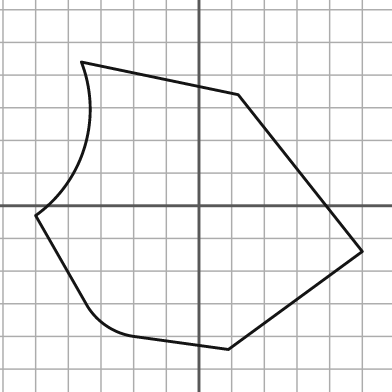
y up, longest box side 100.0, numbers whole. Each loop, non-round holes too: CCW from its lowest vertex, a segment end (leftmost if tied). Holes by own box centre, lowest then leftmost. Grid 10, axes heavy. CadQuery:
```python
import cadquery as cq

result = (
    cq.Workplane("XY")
    .moveTo(9.0, -44.0)
    .lineTo(50.0, -14.0)
    .lineTo(12.0, 34.0)
    .lineTo(-36.0, 44.0)
    .threePointArc((-35.0, 18.0), (-50.0, -3.0))
    .lineTo(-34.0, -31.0)
    .threePointArc((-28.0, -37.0), (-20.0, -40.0))
    .close()
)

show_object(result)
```